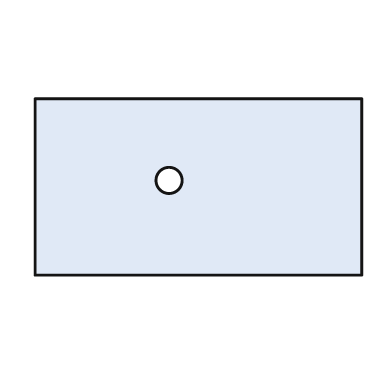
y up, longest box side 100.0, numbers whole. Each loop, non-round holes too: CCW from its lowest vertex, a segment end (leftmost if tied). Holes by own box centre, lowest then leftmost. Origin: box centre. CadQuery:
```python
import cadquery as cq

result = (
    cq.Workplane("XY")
    .moveTo(-50.0, -27.0)
    .lineTo(50.0, -27.0)
    .lineTo(50.0, 27.0)
    .lineTo(-50.0, 27.0)
    .close()
    .moveTo(-9.0, 2.0)
    .circle(4.0)
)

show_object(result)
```